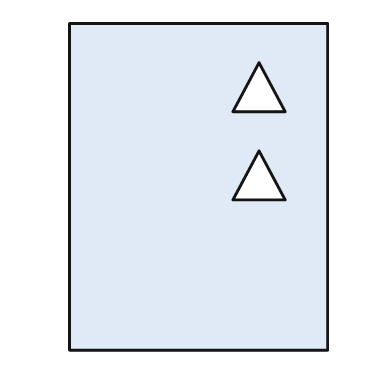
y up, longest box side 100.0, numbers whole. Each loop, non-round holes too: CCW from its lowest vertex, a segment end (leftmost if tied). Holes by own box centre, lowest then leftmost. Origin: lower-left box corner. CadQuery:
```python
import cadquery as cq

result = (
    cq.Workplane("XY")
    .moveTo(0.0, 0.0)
    .lineTo(79.0, 0.0)
    .lineTo(79.0, 100.0)
    .lineTo(0.0, 100.0)
    .close()
    .moveTo(50.0, 46.0)
    .lineTo(66.0, 46.0)
    .lineTo(58.0, 61.0)
    .close()
    .moveTo(50.0, 73.0)
    .lineTo(66.0, 73.0)
    .lineTo(58.0, 88.0)
    .close()
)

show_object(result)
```